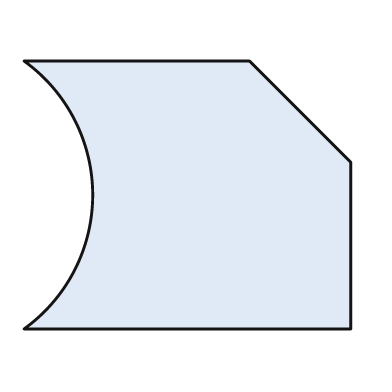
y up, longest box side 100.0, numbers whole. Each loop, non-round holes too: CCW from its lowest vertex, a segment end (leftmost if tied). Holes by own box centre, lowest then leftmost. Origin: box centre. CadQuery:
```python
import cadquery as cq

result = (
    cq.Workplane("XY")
    .moveTo(-50.0, -41.0)
    .lineTo(50.0, -41.0)
    .lineTo(50.0, 10.0)
    .lineTo(19.0, 41.0)
    .lineTo(-50.0, 41.0)
    .threePointArc((-29.0, 0.0), (-50.0, -41.0))
    .close()
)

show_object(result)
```